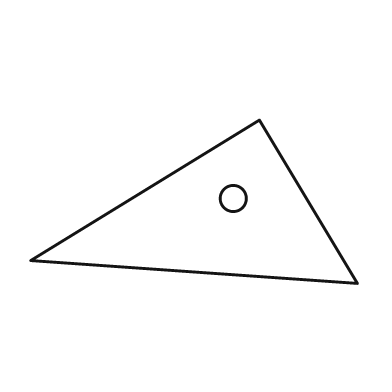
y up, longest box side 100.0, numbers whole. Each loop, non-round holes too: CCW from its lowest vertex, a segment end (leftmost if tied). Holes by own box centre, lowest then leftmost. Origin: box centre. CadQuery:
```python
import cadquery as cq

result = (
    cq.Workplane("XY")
    .moveTo(50.0, -25.0)
    .lineTo(20.0, 25.0)
    .lineTo(-50.0, -18.0)
    .close()
    .moveTo(12.0, 1.0)
    .circle(4.0)
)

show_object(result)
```